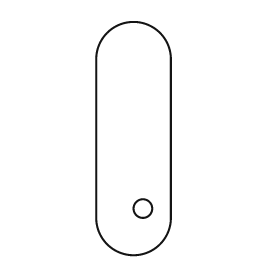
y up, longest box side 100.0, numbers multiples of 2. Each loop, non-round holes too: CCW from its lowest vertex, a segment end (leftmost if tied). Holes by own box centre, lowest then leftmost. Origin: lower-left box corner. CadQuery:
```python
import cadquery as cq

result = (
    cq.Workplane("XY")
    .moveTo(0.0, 16.0)
    .threePointArc((16.0, 0.0), (32.0, 16.0))
    .lineTo(32.0, 84.0)
    .threePointArc((16.0, 100.0), (0.0, 84.0))
    .close()
    .moveTo(20.0, 20.0)
    .circle(4.0)
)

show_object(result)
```